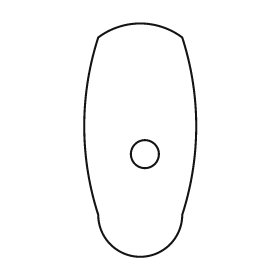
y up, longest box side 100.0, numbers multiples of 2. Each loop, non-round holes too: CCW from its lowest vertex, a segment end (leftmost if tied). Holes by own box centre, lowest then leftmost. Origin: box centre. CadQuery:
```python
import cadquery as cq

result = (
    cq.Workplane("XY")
    .moveTo(-18.0, -32.0)
    .threePointArc((0.0, -50.0), (18.0, -32.0))
    .threePointArc((24.0, 6.0), (18.0, 44.0))
    .threePointArc((0.0, 50.0), (-18.0, 44.0))
    .threePointArc((-24.0, 6.0), (-18.0, -32.0))
    .close()
    .moveTo(2.0, -6.0)
    .circle(6.0)
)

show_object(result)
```